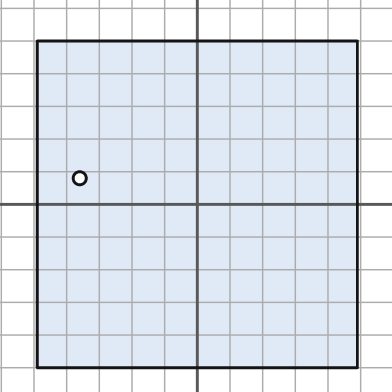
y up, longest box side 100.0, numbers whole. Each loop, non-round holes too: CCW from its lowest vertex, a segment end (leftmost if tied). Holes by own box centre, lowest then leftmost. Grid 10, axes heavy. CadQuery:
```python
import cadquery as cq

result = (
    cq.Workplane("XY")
    .moveTo(-49.0, -50.0)
    .lineTo(49.0, -50.0)
    .lineTo(49.0, 50.0)
    .lineTo(-49.0, 50.0)
    .close()
    .moveTo(-36.0, 8.0)
    .circle(2.0)
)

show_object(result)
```